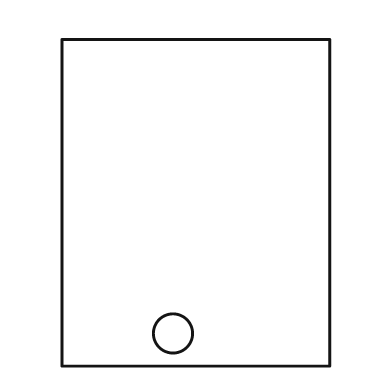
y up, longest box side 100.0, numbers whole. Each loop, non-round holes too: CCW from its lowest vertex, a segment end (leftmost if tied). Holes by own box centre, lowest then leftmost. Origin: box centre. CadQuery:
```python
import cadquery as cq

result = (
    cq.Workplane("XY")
    .moveTo(-41.0, -50.0)
    .lineTo(41.0, -50.0)
    .lineTo(41.0, 50.0)
    .lineTo(-41.0, 50.0)
    .close()
    .moveTo(-7.0, -40.0)
    .circle(6.0)
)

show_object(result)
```